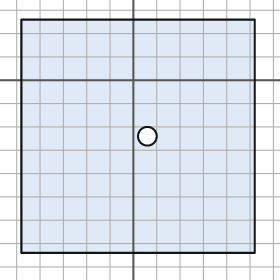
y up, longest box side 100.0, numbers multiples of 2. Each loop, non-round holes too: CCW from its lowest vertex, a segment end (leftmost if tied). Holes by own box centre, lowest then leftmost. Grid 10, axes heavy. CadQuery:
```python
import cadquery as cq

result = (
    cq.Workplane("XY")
    .moveTo(-48.0, -74.0)
    .lineTo(52.0, -74.0)
    .lineTo(52.0, 26.0)
    .lineTo(-48.0, 26.0)
    .close()
    .moveTo(6.0, -24.0)
    .circle(4.0)
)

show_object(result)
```